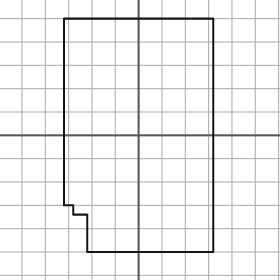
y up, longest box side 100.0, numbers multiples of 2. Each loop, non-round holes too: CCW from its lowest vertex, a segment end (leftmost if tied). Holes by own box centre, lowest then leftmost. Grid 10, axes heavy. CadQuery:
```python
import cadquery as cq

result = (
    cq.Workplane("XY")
    .moveTo(-22.0, -50.0)
    .lineTo(32.0, -50.0)
    .lineTo(32.0, 50.0)
    .lineTo(-32.0, 50.0)
    .lineTo(-32.0, -30.0)
    .lineTo(-28.0, -30.0)
    .lineTo(-28.0, -34.0)
    .lineTo(-22.0, -34.0)
    .close()
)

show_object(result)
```